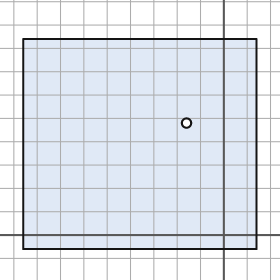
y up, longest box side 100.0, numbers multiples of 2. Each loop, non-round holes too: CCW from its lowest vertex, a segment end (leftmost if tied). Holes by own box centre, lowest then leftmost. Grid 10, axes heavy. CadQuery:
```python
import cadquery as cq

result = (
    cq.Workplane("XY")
    .moveTo(-86.0, -6.0)
    .lineTo(14.0, -6.0)
    .lineTo(14.0, 84.0)
    .lineTo(-86.0, 84.0)
    .close()
    .moveTo(-16.0, 48.0)
    .circle(2.0)
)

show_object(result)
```